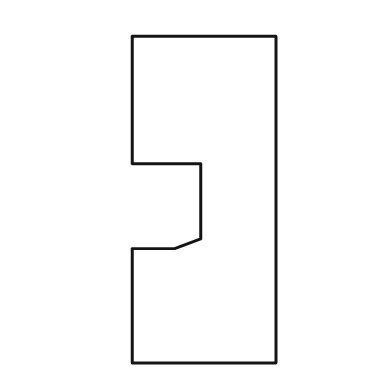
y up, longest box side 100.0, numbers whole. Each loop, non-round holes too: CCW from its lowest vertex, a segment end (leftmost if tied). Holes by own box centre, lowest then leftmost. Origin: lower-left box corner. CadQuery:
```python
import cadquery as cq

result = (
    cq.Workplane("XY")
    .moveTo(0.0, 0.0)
    .lineTo(44.0, 0.0)
    .lineTo(44.0, 100.0)
    .lineTo(0.0, 100.0)
    .lineTo(0.0, 61.0)
    .lineTo(21.0, 61.0)
    .lineTo(21.0, 38.0)
    .lineTo(13.0, 35.0)
    .lineTo(0.0, 35.0)
    .close()
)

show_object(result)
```